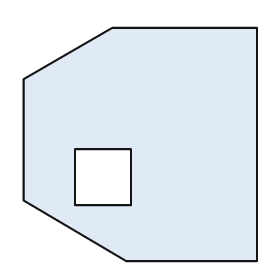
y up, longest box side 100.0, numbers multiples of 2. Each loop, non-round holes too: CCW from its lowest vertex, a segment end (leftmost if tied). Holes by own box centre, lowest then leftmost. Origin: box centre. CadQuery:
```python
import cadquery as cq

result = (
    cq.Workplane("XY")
    .moveTo(-6.0, -50.0)
    .lineTo(50.0, -50.0)
    .lineTo(50.0, 50.0)
    .lineTo(-12.0, 50.0)
    .lineTo(-50.0, 28.0)
    .lineTo(-50.0, -24.0)
    .close()
    .moveTo(-28.0, -26.0)
    .lineTo(-4.0, -26.0)
    .lineTo(-4.0, -2.0)
    .lineTo(-28.0, -2.0)
    .close()
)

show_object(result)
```